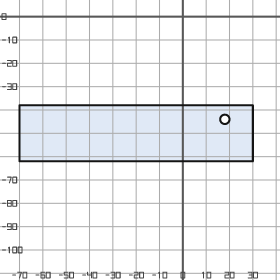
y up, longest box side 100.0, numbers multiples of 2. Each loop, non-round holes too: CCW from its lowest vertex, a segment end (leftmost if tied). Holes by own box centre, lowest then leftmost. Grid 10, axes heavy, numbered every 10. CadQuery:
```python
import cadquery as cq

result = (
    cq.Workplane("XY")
    .moveTo(-70.0, -62.0)
    .lineTo(30.0, -62.0)
    .lineTo(30.0, -38.0)
    .lineTo(-70.0, -38.0)
    .close()
    .moveTo(18.0, -44.0)
    .circle(2.0)
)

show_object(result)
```